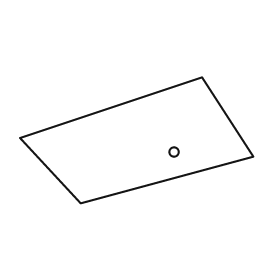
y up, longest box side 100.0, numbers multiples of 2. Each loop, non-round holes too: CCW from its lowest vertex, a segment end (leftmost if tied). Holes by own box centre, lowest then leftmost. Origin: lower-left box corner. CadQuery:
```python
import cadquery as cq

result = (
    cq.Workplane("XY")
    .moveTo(26.0, 0.0)
    .lineTo(100.0, 20.0)
    .lineTo(78.0, 54.0)
    .lineTo(0.0, 28.0)
    .close()
    .moveTo(66.0, 22.0)
    .circle(2.0)
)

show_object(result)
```